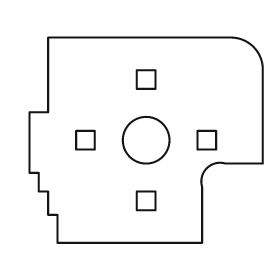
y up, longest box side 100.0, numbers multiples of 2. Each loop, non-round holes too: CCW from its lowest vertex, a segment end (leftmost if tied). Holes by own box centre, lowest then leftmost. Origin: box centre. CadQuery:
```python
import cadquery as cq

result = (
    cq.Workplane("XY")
    .moveTo(-38.0, -44.0)
    .lineTo(24.0, -44.0)
    .lineTo(24.0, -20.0)
    .threePointArc((26.0, -12.0), (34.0, -10.0))
    .lineTo(50.0, -10.0)
    .lineTo(50.0, 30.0)
    .threePointArc((46.0, 40.0), (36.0, 44.0))
    .lineTo(-42.0, 44.0)
    .lineTo(-42.0, 12.0)
    .lineTo(-50.0, 12.0)
    .lineTo(-50.0, -14.0)
    .lineTo(-46.0, -14.0)
    .lineTo(-46.0, -22.0)
    .lineTo(-42.0, -22.0)
    .lineTo(-42.0, -32.0)
    .lineTo(-38.0, -32.0)
    .close()
    .moveTo(-4.0, -30.0)
    .lineTo(4.0, -30.0)
    .lineTo(4.0, -22.0)
    .lineTo(-4.0, -22.0)
    .close()
    .moveTo(-30.0, -4.0)
    .lineTo(-22.0, -4.0)
    .lineTo(-22.0, 4.0)
    .lineTo(-30.0, 4.0)
    .close()
    .moveTo(0.0, 0.0)
    .circle(10.0)
    .moveTo(22.0, -4.0)
    .lineTo(30.0, -4.0)
    .lineTo(30.0, 4.0)
    .lineTo(22.0, 4.0)
    .close()
    .moveTo(-4.0, 22.0)
    .lineTo(4.0, 22.0)
    .lineTo(4.0, 30.0)
    .lineTo(-4.0, 30.0)
    .close()
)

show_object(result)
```